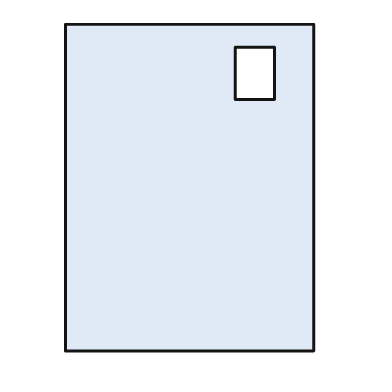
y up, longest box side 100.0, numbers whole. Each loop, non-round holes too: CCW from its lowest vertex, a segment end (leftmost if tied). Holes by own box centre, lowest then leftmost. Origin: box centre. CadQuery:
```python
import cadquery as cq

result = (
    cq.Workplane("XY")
    .moveTo(-38.0, -50.0)
    .lineTo(38.0, -50.0)
    .lineTo(38.0, 50.0)
    .lineTo(-38.0, 50.0)
    .close()
    .moveTo(14.0, 27.0)
    .lineTo(26.0, 27.0)
    .lineTo(26.0, 43.0)
    .lineTo(14.0, 43.0)
    .close()
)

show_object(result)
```